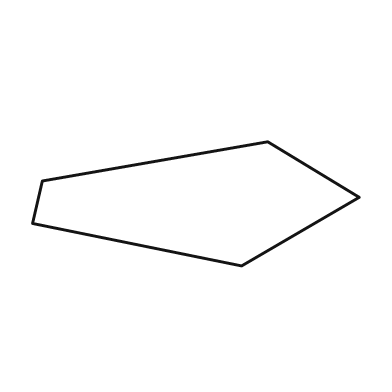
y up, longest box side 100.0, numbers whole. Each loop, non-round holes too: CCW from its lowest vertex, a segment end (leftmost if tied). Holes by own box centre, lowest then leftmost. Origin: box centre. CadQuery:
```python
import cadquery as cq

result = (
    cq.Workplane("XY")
    .moveTo(14.0, -19.0)
    .lineTo(50.0, 2.0)
    .lineTo(22.0, 19.0)
    .lineTo(-47.0, 7.0)
    .lineTo(-50.0, -6.0)
    .close()
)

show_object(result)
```